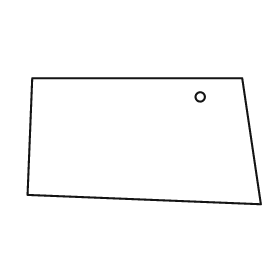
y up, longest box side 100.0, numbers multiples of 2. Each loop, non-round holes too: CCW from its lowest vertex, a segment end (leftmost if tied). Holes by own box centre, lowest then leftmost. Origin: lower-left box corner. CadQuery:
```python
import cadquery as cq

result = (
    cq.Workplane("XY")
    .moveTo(100.0, 0.0)
    .lineTo(92.0, 54.0)
    .lineTo(2.0, 54.0)
    .lineTo(0.0, 4.0)
    .close()
    .moveTo(74.0, 46.0)
    .circle(2.0)
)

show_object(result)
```